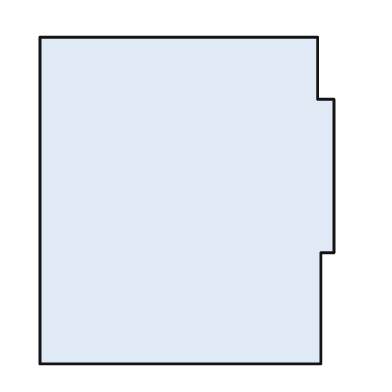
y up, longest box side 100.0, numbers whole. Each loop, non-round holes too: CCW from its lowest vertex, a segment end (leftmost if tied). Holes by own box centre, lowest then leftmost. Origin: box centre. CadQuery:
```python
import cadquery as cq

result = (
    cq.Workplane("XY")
    .moveTo(-45.0, -50.0)
    .lineTo(41.0, -50.0)
    .lineTo(41.0, -16.0)
    .lineTo(45.0, -16.0)
    .lineTo(45.0, 31.0)
    .lineTo(40.0, 31.0)
    .lineTo(40.0, 50.0)
    .lineTo(-45.0, 50.0)
    .close()
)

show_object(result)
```